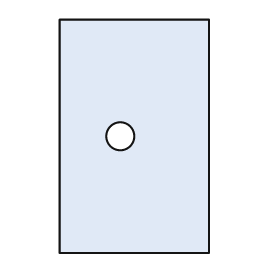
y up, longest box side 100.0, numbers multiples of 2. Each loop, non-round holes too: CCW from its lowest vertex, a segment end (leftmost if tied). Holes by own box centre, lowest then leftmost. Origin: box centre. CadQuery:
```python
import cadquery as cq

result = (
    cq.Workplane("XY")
    .moveTo(-32.0, -50.0)
    .lineTo(32.0, -50.0)
    .lineTo(32.0, 50.0)
    .lineTo(-32.0, 50.0)
    .close()
    .moveTo(-6.0, 0.0)
    .circle(6.0)
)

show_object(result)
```